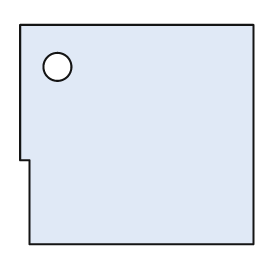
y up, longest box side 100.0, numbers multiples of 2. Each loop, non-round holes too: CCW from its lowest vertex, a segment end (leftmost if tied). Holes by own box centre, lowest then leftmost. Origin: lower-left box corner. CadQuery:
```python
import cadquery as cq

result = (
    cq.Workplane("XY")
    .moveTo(4.0, 0.0)
    .lineTo(100.0, 0.0)
    .lineTo(100.0, 94.0)
    .lineTo(0.0, 94.0)
    .lineTo(0.0, 36.0)
    .lineTo(4.0, 36.0)
    .close()
    .moveTo(16.0, 76.0)
    .circle(6.0)
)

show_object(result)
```